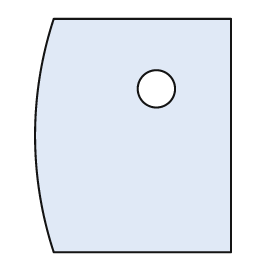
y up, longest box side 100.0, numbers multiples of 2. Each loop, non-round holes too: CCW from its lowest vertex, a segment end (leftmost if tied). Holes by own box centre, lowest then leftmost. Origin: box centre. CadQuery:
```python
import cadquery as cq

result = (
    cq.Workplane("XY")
    .moveTo(-34.0, -50.0)
    .lineTo(42.0, -50.0)
    .lineTo(42.0, 50.0)
    .lineTo(-34.0, 50.0)
    .threePointArc((-42.0, 0.0), (-34.0, -50.0))
    .close()
    .moveTo(10.0, 20.0)
    .circle(8.0)
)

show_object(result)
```